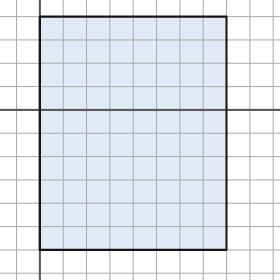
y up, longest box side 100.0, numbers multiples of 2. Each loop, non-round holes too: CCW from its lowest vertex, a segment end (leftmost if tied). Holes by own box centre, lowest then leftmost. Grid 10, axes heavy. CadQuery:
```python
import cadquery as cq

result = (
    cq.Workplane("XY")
    .moveTo(0.0, -60.0)
    .lineTo(80.0, -60.0)
    .lineTo(80.0, 40.0)
    .lineTo(0.0, 40.0)
    .close()
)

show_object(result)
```